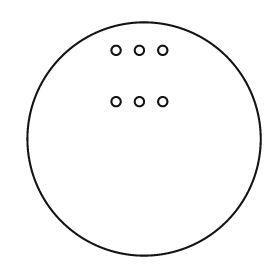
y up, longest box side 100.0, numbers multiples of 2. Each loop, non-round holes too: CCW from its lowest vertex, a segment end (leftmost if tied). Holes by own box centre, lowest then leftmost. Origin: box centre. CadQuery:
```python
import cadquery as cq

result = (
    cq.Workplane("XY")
    .moveTo(0.0, 0.0)
    .circle(50.0)
    .moveTo(-12.0, 16.0)
    .circle(2.0)
    .moveTo(-2.0, 16.0)
    .circle(2.0)
    .moveTo(8.0, 16.0)
    .circle(2.0)
    .moveTo(-12.0, 38.0)
    .circle(2.0)
    .moveTo(-2.0, 38.0)
    .circle(2.0)
    .moveTo(8.0, 38.0)
    .circle(2.0)
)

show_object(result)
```